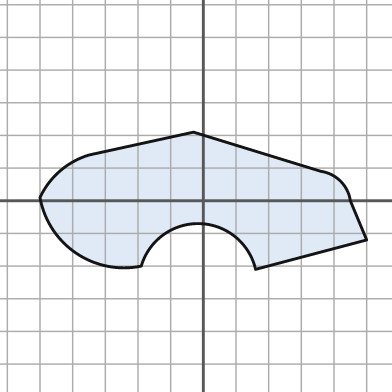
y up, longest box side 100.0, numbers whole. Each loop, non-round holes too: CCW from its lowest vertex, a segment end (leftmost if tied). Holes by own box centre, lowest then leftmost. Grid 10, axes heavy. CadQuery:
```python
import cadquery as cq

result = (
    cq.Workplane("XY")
    .moveTo(16.0, -21.0)
    .lineTo(50.0, -12.0)
    .lineTo(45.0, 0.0)
    .threePointArc((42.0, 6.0), (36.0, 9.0))
    .lineTo(-3.0, 21.0)
    .lineTo(-35.0, 14.0)
    .threePointArc((-44.0, 9.0), (-50.0, 1.0))
    .threePointArc((-39.0, -16.0), (-19.0, -20.0))
    .threePointArc((-1.0, -7.0), (16.0, -21.0))
    .close()
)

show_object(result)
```